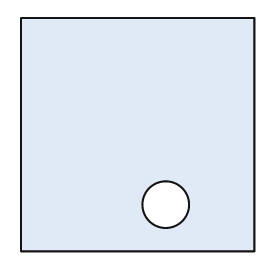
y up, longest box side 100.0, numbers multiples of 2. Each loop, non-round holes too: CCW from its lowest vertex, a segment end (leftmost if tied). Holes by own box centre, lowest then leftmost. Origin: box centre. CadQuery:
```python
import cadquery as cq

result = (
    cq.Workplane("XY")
    .moveTo(-50.0, -50.0)
    .lineTo(50.0, -50.0)
    .lineTo(50.0, 50.0)
    .lineTo(-50.0, 50.0)
    .close()
    .moveTo(12.0, -30.0)
    .circle(10.0)
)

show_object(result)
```